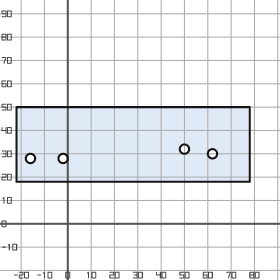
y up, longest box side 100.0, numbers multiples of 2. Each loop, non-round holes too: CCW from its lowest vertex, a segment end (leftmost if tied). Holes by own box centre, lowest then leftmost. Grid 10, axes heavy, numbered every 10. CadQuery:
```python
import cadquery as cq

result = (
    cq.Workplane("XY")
    .moveTo(-22.0, 18.0)
    .lineTo(78.0, 18.0)
    .lineTo(78.0, 50.0)
    .lineTo(-22.0, 50.0)
    .close()
    .moveTo(-16.0, 28.0)
    .circle(2.0)
    .moveTo(-2.0, 28.0)
    .circle(2.0)
    .moveTo(62.0, 30.0)
    .circle(2.0)
    .moveTo(50.0, 32.0)
    .circle(2.0)
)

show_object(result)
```